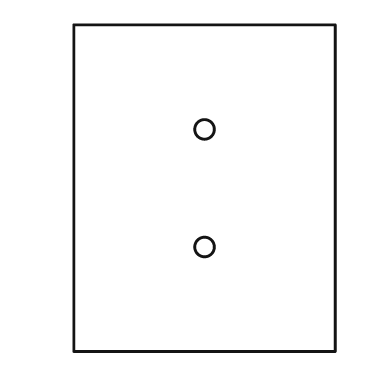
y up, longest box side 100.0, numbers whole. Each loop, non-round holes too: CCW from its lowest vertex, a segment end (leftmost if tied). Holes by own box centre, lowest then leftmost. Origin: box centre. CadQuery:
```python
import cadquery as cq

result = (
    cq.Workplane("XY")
    .moveTo(-40.0, -50.0)
    .lineTo(40.0, -50.0)
    .lineTo(40.0, 50.0)
    .lineTo(-40.0, 50.0)
    .close()
    .moveTo(0.0, -18.0)
    .circle(3.0)
    .moveTo(0.0, 18.0)
    .circle(3.0)
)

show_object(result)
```